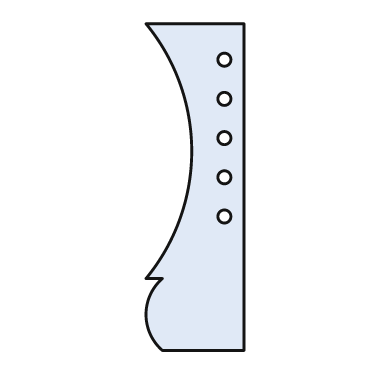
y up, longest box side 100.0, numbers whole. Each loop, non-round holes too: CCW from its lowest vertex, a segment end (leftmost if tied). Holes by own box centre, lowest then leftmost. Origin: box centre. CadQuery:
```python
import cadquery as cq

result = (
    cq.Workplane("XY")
    .moveTo(-10.0, -50.0)
    .lineTo(15.0, -50.0)
    .lineTo(15.0, 50.0)
    .lineTo(-15.0, 50.0)
    .threePointArc((-1.0, 11.0), (-15.0, -28.0))
    .lineTo(-10.0, -28.0)
    .threePointArc((-15.0, -39.0), (-10.0, -50.0))
    .close()
    .moveTo(9.0, -9.0)
    .circle(2.0)
    .moveTo(9.0, 3.0)
    .circle(2.0)
    .moveTo(9.0, 15.0)
    .circle(2.0)
    .moveTo(9.0, 27.0)
    .circle(2.0)
    .moveTo(9.0, 39.0)
    .circle(2.0)
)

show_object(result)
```